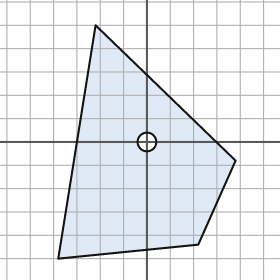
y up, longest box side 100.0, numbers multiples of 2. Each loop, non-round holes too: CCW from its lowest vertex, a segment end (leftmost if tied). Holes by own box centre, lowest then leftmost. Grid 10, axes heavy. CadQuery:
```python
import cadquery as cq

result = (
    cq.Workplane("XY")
    .moveTo(-38.0, -50.0)
    .lineTo(22.0, -44.0)
    .lineTo(38.0, -8.0)
    .lineTo(-22.0, 50.0)
    .close()
    .moveTo(0.0, 0.0)
    .circle(4.0)
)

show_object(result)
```